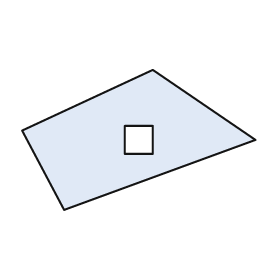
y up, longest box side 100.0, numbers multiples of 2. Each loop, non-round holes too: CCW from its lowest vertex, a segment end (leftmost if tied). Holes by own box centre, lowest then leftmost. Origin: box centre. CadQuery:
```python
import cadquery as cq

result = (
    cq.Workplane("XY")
    .moveTo(-32.0, -30.0)
    .lineTo(50.0, 0.0)
    .lineTo(6.0, 30.0)
    .lineTo(-50.0, 4.0)
    .close()
    .moveTo(-6.0, -6.0)
    .lineTo(6.0, -6.0)
    .lineTo(6.0, 6.0)
    .lineTo(-6.0, 6.0)
    .close()
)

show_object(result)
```